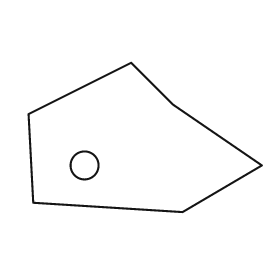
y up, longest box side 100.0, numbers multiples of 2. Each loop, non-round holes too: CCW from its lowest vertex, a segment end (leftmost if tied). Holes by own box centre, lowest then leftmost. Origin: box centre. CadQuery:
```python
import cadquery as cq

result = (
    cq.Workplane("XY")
    .moveTo(16.0, -32.0)
    .lineTo(50.0, -12.0)
    .lineTo(12.0, 14.0)
    .lineTo(-6.0, 32.0)
    .lineTo(-50.0, 10.0)
    .lineTo(-48.0, -28.0)
    .close()
    .moveTo(-26.0, -12.0)
    .circle(6.0)
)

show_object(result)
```